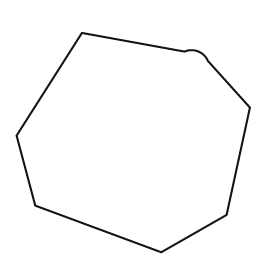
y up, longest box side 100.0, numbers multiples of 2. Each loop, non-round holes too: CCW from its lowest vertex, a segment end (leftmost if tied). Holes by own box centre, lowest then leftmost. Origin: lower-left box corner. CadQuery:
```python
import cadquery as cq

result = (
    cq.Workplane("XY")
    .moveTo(62.0, 0.0)
    .lineTo(90.0, 16.0)
    .lineTo(100.0, 62.0)
    .lineTo(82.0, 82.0)
    .threePointArc((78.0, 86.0), (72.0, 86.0))
    .lineTo(28.0, 94.0)
    .lineTo(0.0, 50.0)
    .lineTo(8.0, 20.0)
    .close()
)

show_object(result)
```